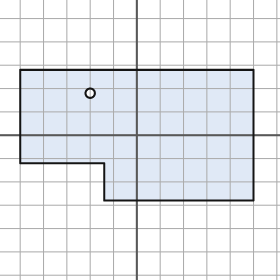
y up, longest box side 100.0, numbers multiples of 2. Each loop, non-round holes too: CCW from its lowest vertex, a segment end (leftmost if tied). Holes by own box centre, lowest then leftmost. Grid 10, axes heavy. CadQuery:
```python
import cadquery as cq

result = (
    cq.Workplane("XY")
    .moveTo(-14.0, -28.0)
    .lineTo(50.0, -28.0)
    .lineTo(50.0, 28.0)
    .lineTo(-50.0, 28.0)
    .lineTo(-50.0, -12.0)
    .lineTo(-14.0, -12.0)
    .close()
    .moveTo(-20.0, 18.0)
    .circle(2.0)
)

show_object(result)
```